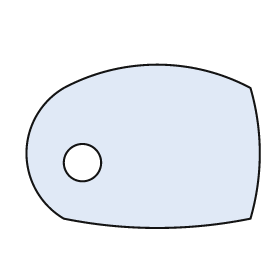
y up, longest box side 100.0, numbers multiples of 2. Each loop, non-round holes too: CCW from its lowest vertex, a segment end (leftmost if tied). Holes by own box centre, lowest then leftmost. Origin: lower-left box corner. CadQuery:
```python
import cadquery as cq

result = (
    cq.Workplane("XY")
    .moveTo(16.0, 4.0)
    .threePointArc((56.0, 0.0), (96.0, 4.0))
    .threePointArc((100.0, 32.0), (96.0, 60.0))
    .threePointArc((56.0, 70.0), (16.0, 60.0))
    .threePointArc((0.0, 32.0), (16.0, 4.0))
    .close()
    .moveTo(24.0, 28.0)
    .circle(8.0)
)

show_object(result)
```